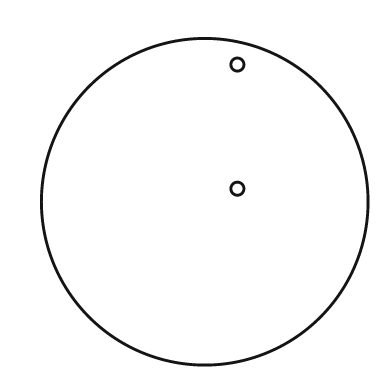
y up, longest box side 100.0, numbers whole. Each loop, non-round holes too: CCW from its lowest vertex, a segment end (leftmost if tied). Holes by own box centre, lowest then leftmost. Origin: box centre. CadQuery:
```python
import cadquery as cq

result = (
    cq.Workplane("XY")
    .moveTo(0.0, 0.0)
    .circle(50.0)
    .moveTo(10.0, 4.0)
    .circle(2.0)
    .moveTo(10.0, 42.0)
    .circle(2.0)
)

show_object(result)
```